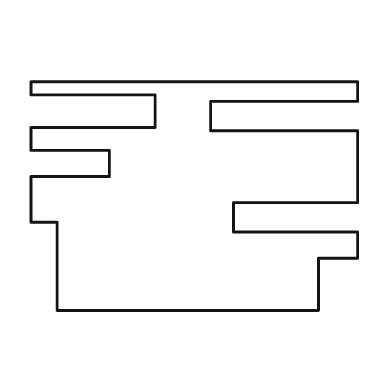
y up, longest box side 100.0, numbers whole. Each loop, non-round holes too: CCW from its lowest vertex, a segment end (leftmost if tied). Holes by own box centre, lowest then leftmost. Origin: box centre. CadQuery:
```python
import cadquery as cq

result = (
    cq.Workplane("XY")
    .moveTo(-42.0, -35.0)
    .lineTo(38.0, -35.0)
    .lineTo(38.0, -19.0)
    .lineTo(50.0, -19.0)
    .lineTo(50.0, -11.0)
    .lineTo(12.0, -11.0)
    .lineTo(12.0, -2.0)
    .lineTo(50.0, -2.0)
    .lineTo(50.0, 20.0)
    .lineTo(5.0, 20.0)
    .lineTo(5.0, 29.0)
    .lineTo(50.0, 29.0)
    .lineTo(50.0, 35.0)
    .lineTo(-50.0, 35.0)
    .lineTo(-50.0, 31.0)
    .lineTo(-12.0, 31.0)
    .lineTo(-12.0, 21.0)
    .lineTo(-50.0, 21.0)
    .lineTo(-50.0, 14.0)
    .lineTo(-26.0, 14.0)
    .lineTo(-26.0, 6.0)
    .lineTo(-50.0, 6.0)
    .lineTo(-50.0, -8.0)
    .lineTo(-42.0, -8.0)
    .close()
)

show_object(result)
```